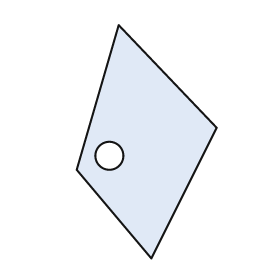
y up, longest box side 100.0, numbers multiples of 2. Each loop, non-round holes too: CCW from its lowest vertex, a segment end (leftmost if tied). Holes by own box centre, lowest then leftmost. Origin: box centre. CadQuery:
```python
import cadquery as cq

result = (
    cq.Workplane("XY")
    .moveTo(2.0, -50.0)
    .lineTo(30.0, 6.0)
    .lineTo(-12.0, 50.0)
    .lineTo(-30.0, -12.0)
    .close()
    .moveTo(-16.0, -6.0)
    .circle(6.0)
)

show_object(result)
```